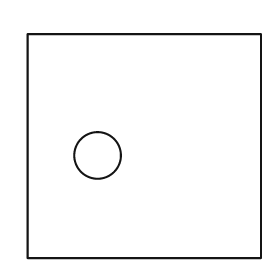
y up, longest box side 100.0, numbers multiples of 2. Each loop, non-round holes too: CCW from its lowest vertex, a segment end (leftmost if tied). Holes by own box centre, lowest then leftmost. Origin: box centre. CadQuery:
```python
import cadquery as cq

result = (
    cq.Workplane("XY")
    .moveTo(-50.0, -48.0)
    .lineTo(50.0, -48.0)
    .lineTo(50.0, 48.0)
    .lineTo(-50.0, 48.0)
    .close()
    .moveTo(-20.0, -4.0)
    .circle(10.0)
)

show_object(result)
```